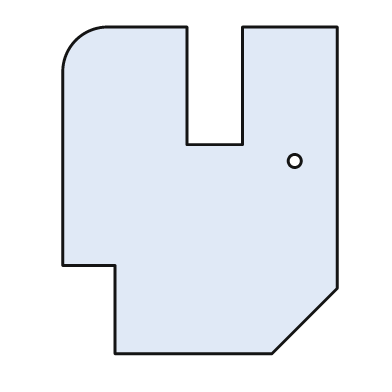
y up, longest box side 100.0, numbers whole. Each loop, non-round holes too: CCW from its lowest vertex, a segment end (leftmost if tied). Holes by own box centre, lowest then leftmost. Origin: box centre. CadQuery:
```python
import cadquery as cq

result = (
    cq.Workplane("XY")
    .moveTo(-26.0, -50.0)
    .lineTo(22.0, -50.0)
    .lineTo(42.0, -30.0)
    .lineTo(42.0, 50.0)
    .lineTo(13.0, 50.0)
    .lineTo(13.0, 14.0)
    .lineTo(-4.0, 14.0)
    .lineTo(-4.0, 50.0)
    .lineTo(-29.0, 50.0)
    .threePointArc((-38.0, 46.0), (-42.0, 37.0))
    .lineTo(-42.0, -23.0)
    .lineTo(-26.0, -23.0)
    .close()
    .moveTo(29.0, 9.0)
    .circle(2.0)
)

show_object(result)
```